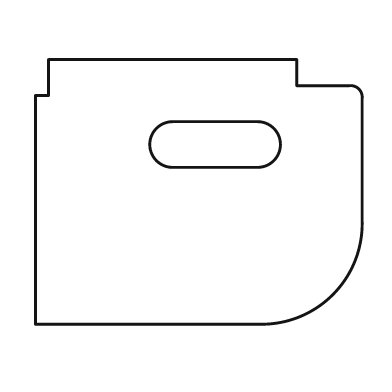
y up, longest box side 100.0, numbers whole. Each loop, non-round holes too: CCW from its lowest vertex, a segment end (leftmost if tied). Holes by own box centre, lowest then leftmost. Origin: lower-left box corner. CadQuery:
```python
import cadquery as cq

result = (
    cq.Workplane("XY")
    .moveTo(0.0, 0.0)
    .lineTo(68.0, 0.0)
    .threePointArc((91.0, 9.0), (100.0, 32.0))
    .lineTo(100.0, 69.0)
    .threePointArc((99.0, 72.0), (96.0, 73.0))
    .lineTo(80.0, 73.0)
    .lineTo(80.0, 81.0)
    .lineTo(4.0, 81.0)
    .lineTo(4.0, 70.0)
    .lineTo(0.0, 70.0)
    .close()
    .moveTo(42.0, 48.0)
    .lineTo(68.0, 48.0)
    .threePointArc((75.0, 55.0), (68.0, 62.0))
    .lineTo(42.0, 62.0)
    .threePointArc((35.0, 55.0), (42.0, 48.0))
    .close()
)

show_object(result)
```